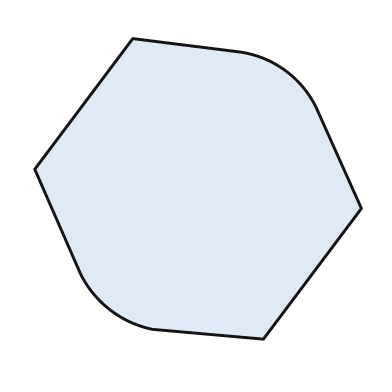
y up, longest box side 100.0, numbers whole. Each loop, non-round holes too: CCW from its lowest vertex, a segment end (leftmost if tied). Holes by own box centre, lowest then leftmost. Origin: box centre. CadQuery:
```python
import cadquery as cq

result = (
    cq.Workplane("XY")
    .moveTo(20.0, -46.0)
    .lineTo(50.0, -6.0)
    .lineTo(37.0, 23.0)
    .threePointArc((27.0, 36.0), (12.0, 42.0))
    .lineTo(-20.0, 46.0)
    .lineTo(-50.0, 6.0)
    .lineTo(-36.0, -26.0)
    .threePointArc((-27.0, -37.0), (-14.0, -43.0))
    .close()
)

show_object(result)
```